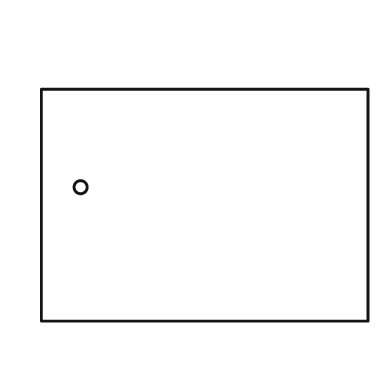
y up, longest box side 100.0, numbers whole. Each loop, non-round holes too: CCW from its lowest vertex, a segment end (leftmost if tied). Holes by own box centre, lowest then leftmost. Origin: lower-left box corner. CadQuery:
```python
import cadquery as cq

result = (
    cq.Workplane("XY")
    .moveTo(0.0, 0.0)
    .lineTo(100.0, 0.0)
    .lineTo(100.0, 71.0)
    .lineTo(0.0, 71.0)
    .close()
    .moveTo(12.0, 41.0)
    .circle(2.0)
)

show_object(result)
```